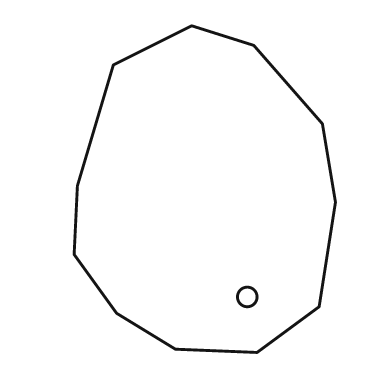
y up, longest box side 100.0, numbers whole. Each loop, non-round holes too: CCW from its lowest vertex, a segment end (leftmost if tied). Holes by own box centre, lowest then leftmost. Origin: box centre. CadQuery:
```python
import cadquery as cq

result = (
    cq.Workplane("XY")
    .moveTo(16.0, -50.0)
    .lineTo(35.0, -36.0)
    .lineTo(40.0, -4.0)
    .lineTo(36.0, 20.0)
    .lineTo(15.0, 44.0)
    .lineTo(-4.0, 50.0)
    .lineTo(-28.0, 38.0)
    .lineTo(-39.0, 1.0)
    .lineTo(-40.0, -20.0)
    .lineTo(-27.0, -38.0)
    .lineTo(-9.0, -49.0)
    .close()
    .moveTo(13.0, -33.0)
    .circle(3.0)
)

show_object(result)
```